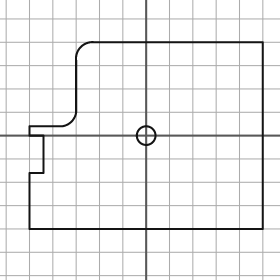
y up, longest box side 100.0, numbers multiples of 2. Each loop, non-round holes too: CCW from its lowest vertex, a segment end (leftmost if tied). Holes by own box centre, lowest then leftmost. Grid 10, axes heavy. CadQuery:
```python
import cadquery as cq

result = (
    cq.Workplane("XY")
    .moveTo(-50.0, -40.0)
    .lineTo(50.0, -40.0)
    .lineTo(50.0, 40.0)
    .lineTo(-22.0, 40.0)
    .threePointArc((-28.0, 38.0), (-30.0, 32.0))
    .lineTo(-30.0, 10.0)
    .threePointArc((-32.0, 6.0), (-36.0, 4.0))
    .lineTo(-50.0, 4.0)
    .lineTo(-50.0, 0.0)
    .lineTo(-44.0, 0.0)
    .lineTo(-44.0, -16.0)
    .lineTo(-50.0, -16.0)
    .close()
    .moveTo(0.0, 0.0)
    .circle(4.0)
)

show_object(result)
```